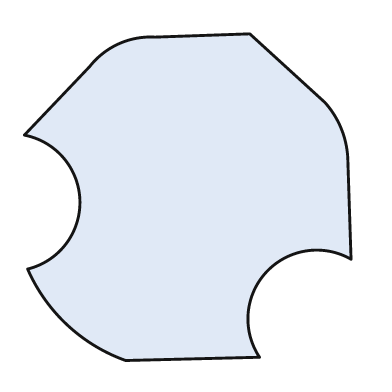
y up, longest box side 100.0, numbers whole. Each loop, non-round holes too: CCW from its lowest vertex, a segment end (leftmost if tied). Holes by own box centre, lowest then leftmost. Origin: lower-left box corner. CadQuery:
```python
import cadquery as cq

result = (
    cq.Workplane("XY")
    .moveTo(31.0, 0.0)
    .lineTo(72.0, 1.0)
    .threePointArc((74.0, 27.0), (100.0, 31.0))
    .lineTo(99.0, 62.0)
    .threePointArc((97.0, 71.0), (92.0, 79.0))
    .lineTo(69.0, 100.0)
    .lineTo(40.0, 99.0)
    .threePointArc((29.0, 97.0), (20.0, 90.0))
    .lineTo(0.0, 69.0)
    .threePointArc((17.0, 49.0), (1.0, 28.0))
    .threePointArc((13.0, 11.0), (31.0, 0.0))
    .close()
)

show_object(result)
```